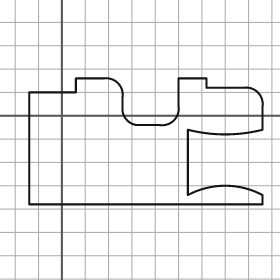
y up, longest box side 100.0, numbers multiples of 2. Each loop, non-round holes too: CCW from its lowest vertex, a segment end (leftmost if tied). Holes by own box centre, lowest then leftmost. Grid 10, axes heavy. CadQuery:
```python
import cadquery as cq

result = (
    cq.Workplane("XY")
    .moveTo(-14.0, -38.0)
    .lineTo(86.0, -38.0)
    .lineTo(86.0, -34.0)
    .threePointArc((70.0, -30.0), (54.0, -34.0))
    .lineTo(54.0, -6.0)
    .threePointArc((70.0, -8.0), (86.0, -6.0))
    .lineTo(86.0, 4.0)
    .threePointArc((84.0, 10.0), (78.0, 12.0))
    .lineTo(62.0, 12.0)
    .lineTo(62.0, 16.0)
    .lineTo(50.0, 16.0)
    .lineTo(50.0, 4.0)
    .threePointArc((48.0, -2.0), (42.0, -4.0))
    .lineTo(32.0, -4.0)
    .threePointArc((28.0, -2.0), (26.0, 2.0))
    .lineTo(26.0, 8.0)
    .threePointArc((24.0, 14.0), (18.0, 16.0))
    .lineTo(6.0, 16.0)
    .lineTo(6.0, 10.0)
    .lineTo(-14.0, 10.0)
    .close()
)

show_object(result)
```